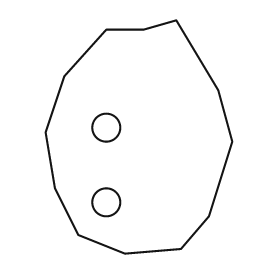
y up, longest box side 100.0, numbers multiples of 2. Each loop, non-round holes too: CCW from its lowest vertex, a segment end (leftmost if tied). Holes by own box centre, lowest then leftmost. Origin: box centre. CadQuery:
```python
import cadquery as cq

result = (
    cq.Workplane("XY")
    .moveTo(-6.0, -50.0)
    .lineTo(18.0, -48.0)
    .lineTo(30.0, -34.0)
    .lineTo(40.0, -2.0)
    .lineTo(34.0, 20.0)
    .lineTo(16.0, 50.0)
    .lineTo(2.0, 46.0)
    .lineTo(-14.0, 46.0)
    .lineTo(-32.0, 26.0)
    .lineTo(-40.0, 2.0)
    .lineTo(-36.0, -22.0)
    .lineTo(-26.0, -42.0)
    .close()
    .moveTo(-14.0, -28.0)
    .circle(6.0)
    .moveTo(-14.0, 4.0)
    .circle(6.0)
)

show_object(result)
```